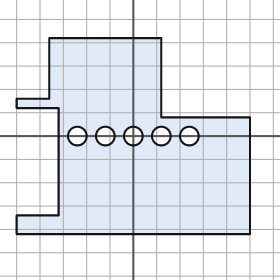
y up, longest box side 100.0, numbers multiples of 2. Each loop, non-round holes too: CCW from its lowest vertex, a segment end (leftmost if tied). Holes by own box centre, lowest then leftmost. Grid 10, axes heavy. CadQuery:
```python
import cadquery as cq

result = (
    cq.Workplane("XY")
    .moveTo(-50.0, -42.0)
    .lineTo(50.0, -42.0)
    .lineTo(50.0, 8.0)
    .lineTo(12.0, 8.0)
    .lineTo(12.0, 42.0)
    .lineTo(-36.0, 42.0)
    .lineTo(-36.0, 16.0)
    .lineTo(-50.0, 16.0)
    .lineTo(-50.0, 12.0)
    .lineTo(-32.0, 12.0)
    .lineTo(-32.0, -34.0)
    .lineTo(-50.0, -34.0)
    .close()
    .moveTo(-24.0, 0.0)
    .circle(4.0)
    .moveTo(-12.0, 0.0)
    .circle(4.0)
    .moveTo(0.0, 0.0)
    .circle(4.0)
    .moveTo(12.0, 0.0)
    .circle(4.0)
    .moveTo(24.0, 0.0)
    .circle(4.0)
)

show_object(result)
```